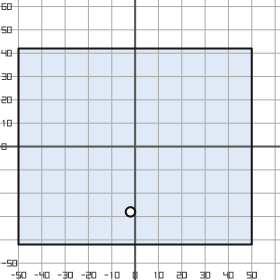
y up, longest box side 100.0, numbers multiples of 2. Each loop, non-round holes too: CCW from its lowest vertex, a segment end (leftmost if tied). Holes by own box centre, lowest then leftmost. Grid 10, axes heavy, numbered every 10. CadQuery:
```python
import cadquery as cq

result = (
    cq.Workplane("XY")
    .moveTo(-50.0, -42.0)
    .lineTo(50.0, -42.0)
    .lineTo(50.0, 42.0)
    .lineTo(-50.0, 42.0)
    .close()
    .moveTo(-2.0, -28.0)
    .circle(2.0)
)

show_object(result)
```